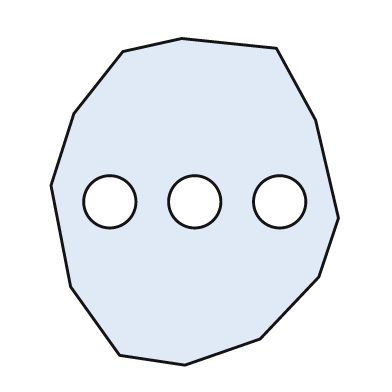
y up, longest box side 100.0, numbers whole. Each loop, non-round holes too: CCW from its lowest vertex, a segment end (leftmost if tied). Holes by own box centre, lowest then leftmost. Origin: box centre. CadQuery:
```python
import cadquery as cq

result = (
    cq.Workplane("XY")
    .moveTo(-3.0, -50.0)
    .lineTo(20.0, -42.0)
    .lineTo(38.0, -23.0)
    .lineTo(44.0, -5.0)
    .lineTo(37.0, 25.0)
    .lineTo(25.0, 47.0)
    .lineTo(-4.0, 50.0)
    .lineTo(-22.0, 46.0)
    .lineTo(-37.0, 27.0)
    .lineTo(-44.0, 5.0)
    .lineTo(-38.0, -26.0)
    .lineTo(-23.0, -47.0)
    .close()
    .moveTo(-26.0, 0.0)
    .circle(8.0)
    .moveTo(0.0, 0.0)
    .circle(8.0)
    .moveTo(26.0, 0.0)
    .circle(8.0)
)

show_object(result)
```